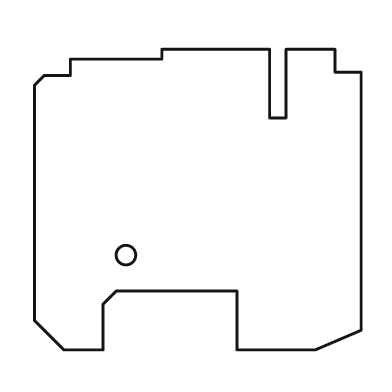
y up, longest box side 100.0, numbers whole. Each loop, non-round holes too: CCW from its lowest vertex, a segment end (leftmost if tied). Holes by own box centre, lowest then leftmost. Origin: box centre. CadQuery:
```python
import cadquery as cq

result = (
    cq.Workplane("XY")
    .moveTo(-41.0, -46.0)
    .lineTo(-29.0, -46.0)
    .lineTo(-29.0, -32.0)
    .lineTo(-25.0, -28.0)
    .lineTo(12.0, -28.0)
    .lineTo(12.0, -46.0)
    .lineTo(36.0, -46.0)
    .lineTo(50.0, -40.0)
    .lineTo(50.0, 39.0)
    .lineTo(42.0, 39.0)
    .lineTo(42.0, 46.0)
    .lineTo(27.0, 46.0)
    .lineTo(27.0, 25.0)
    .lineTo(22.0, 25.0)
    .lineTo(22.0, 46.0)
    .lineTo(-11.0, 46.0)
    .lineTo(-11.0, 43.0)
    .lineTo(-39.0, 43.0)
    .lineTo(-39.0, 38.0)
    .lineTo(-47.0, 38.0)
    .lineTo(-50.0, 35.0)
    .lineTo(-50.0, -37.0)
    .close()
    .moveTo(-22.0, -17.0)
    .circle(3.0)
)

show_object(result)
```